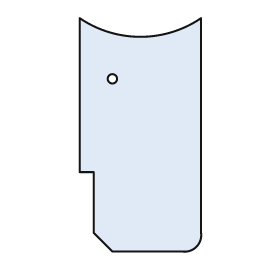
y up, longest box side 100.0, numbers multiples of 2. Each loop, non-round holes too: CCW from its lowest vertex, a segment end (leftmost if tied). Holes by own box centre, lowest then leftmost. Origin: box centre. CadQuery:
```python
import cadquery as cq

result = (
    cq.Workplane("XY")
    .moveTo(-12.0, -50.0)
    .lineTo(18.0, -50.0)
    .threePointArc((24.0, -48.0), (26.0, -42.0))
    .lineTo(26.0, 50.0)
    .threePointArc((0.0, 42.0), (-26.0, 50.0))
    .lineTo(-26.0, -16.0)
    .lineTo(-20.0, -16.0)
    .lineTo(-20.0, -42.0)
    .close()
    .moveTo(-12.0, 24.0)
    .circle(2.0)
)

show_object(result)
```